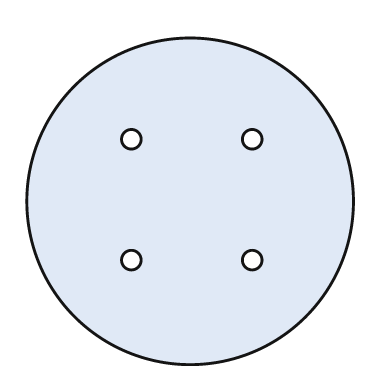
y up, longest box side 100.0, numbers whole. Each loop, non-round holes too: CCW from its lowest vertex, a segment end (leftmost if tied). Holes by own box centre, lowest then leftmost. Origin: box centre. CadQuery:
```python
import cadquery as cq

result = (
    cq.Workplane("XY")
    .moveTo(0.0, 0.0)
    .circle(50.0)
    .moveTo(-18.0, -18.0)
    .circle(3.0)
    .moveTo(19.0, -18.0)
    .circle(3.0)
    .moveTo(-18.0, 19.0)
    .circle(3.0)
    .moveTo(19.0, 19.0)
    .circle(3.0)
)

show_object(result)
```